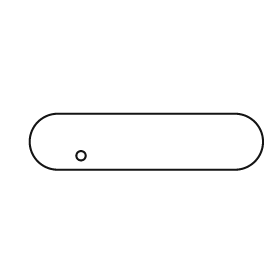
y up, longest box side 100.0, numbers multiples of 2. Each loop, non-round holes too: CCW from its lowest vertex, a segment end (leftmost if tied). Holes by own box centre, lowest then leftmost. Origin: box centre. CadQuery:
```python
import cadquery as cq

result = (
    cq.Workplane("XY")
    .moveTo(-38.0, -12.0)
    .lineTo(38.0, -12.0)
    .threePointArc((50.0, 0.0), (38.0, 12.0))
    .lineTo(-38.0, 12.0)
    .threePointArc((-50.0, 0.0), (-38.0, -12.0))
    .close()
    .moveTo(-28.0, -6.0)
    .circle(2.0)
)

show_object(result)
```